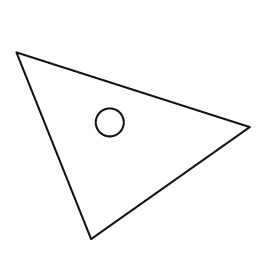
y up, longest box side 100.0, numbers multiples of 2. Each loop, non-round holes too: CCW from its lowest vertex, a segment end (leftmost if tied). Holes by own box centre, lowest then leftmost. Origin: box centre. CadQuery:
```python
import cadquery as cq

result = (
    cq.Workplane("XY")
    .moveTo(-18.0, -40.0)
    .lineTo(50.0, 8.0)
    .lineTo(-50.0, 40.0)
    .close()
    .moveTo(-10.0, 10.0)
    .circle(6.0)
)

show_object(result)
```